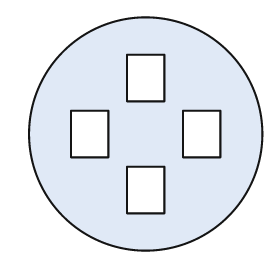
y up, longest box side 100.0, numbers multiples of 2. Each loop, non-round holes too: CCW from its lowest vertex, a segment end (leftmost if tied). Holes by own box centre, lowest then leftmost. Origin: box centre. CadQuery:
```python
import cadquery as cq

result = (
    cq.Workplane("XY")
    .moveTo(0.0, 0.0)
    .circle(50.0)
    .moveTo(-8.0, -34.0)
    .lineTo(8.0, -34.0)
    .lineTo(8.0, -14.0)
    .lineTo(-8.0, -14.0)
    .close()
    .moveTo(-32.0, -10.0)
    .lineTo(-16.0, -10.0)
    .lineTo(-16.0, 10.0)
    .lineTo(-32.0, 10.0)
    .close()
    .moveTo(16.0, -10.0)
    .lineTo(32.0, -10.0)
    .lineTo(32.0, 10.0)
    .lineTo(16.0, 10.0)
    .close()
    .moveTo(-8.0, 14.0)
    .lineTo(8.0, 14.0)
    .lineTo(8.0, 34.0)
    .lineTo(-8.0, 34.0)
    .close()
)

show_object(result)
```